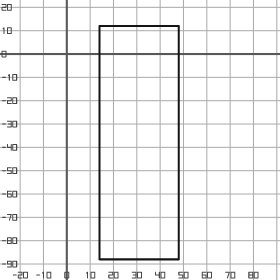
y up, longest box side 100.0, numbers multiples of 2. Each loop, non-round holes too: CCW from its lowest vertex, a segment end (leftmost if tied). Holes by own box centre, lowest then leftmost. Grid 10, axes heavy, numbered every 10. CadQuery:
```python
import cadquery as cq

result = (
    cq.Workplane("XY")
    .moveTo(14.0, -88.0)
    .lineTo(48.0, -88.0)
    .lineTo(48.0, 12.0)
    .lineTo(14.0, 12.0)
    .close()
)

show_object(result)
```